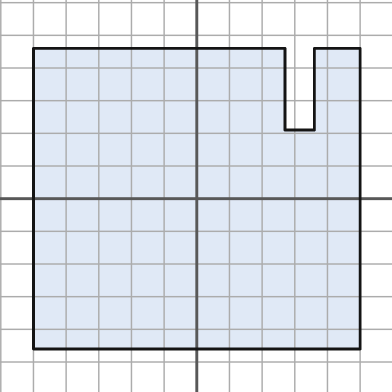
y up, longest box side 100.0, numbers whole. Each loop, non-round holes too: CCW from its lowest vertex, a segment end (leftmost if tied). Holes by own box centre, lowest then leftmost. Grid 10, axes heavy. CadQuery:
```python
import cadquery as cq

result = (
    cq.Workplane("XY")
    .moveTo(-50.0, -46.0)
    .lineTo(50.0, -46.0)
    .lineTo(50.0, 46.0)
    .lineTo(36.0, 46.0)
    .lineTo(36.0, 21.0)
    .lineTo(27.0, 21.0)
    .lineTo(27.0, 46.0)
    .lineTo(-50.0, 46.0)
    .close()
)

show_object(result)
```